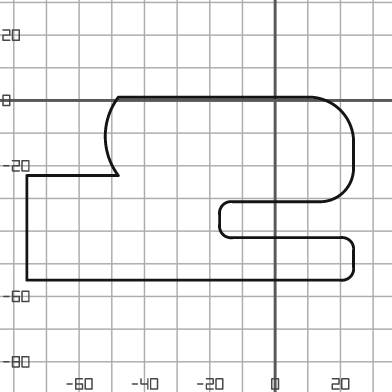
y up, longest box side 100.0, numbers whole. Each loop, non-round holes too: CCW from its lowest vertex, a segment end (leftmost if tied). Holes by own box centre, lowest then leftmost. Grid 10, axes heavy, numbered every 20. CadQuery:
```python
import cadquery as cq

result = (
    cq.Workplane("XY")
    .moveTo(-76.0, -55.0)
    .lineTo(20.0, -55.0)
    .threePointArc((23.0, -54.0), (24.0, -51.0))
    .lineTo(24.0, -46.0)
    .threePointArc((23.0, -43.0), (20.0, -42.0))
    .lineTo(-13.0, -42.0)
    .threePointArc((-16.0, -41.0), (-17.0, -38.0))
    .lineTo(-17.0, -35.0)
    .threePointArc((-16.0, -32.0), (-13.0, -31.0))
    .lineTo(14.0, -31.0)
    .threePointArc((21.0, -28.0), (24.0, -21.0))
    .lineTo(24.0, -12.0)
    .threePointArc((20.0, -3.0), (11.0, 1.0))
    .lineTo(-48.0, 1.0)
    .threePointArc((-52.0, -11.0), (-48.0, -23.0))
    .lineTo(-76.0, -23.0)
    .close()
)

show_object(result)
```